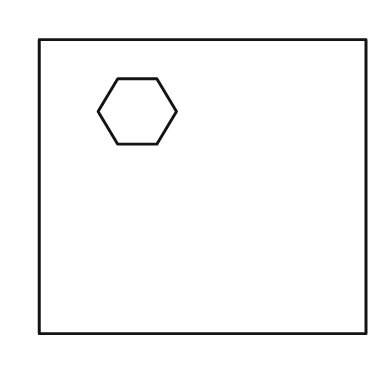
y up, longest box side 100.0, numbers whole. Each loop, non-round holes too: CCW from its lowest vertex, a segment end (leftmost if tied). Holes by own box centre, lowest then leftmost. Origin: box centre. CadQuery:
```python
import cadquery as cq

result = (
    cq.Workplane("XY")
    .moveTo(-50.0, -45.0)
    .lineTo(50.0, -45.0)
    .lineTo(50.0, 45.0)
    .lineTo(-50.0, 45.0)
    .close()
    .moveTo(-26.0, 13.0)
    .lineTo(-14.0, 13.0)
    .lineTo(-8.0, 23.0)
    .lineTo(-14.0, 33.0)
    .lineTo(-26.0, 33.0)
    .lineTo(-32.0, 23.0)
    .close()
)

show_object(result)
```